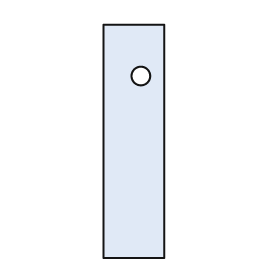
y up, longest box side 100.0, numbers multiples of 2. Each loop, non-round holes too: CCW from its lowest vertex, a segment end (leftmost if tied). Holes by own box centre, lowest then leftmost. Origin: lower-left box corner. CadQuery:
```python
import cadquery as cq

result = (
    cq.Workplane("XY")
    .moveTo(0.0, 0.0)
    .lineTo(26.0, 0.0)
    .lineTo(26.0, 100.0)
    .lineTo(0.0, 100.0)
    .close()
    .moveTo(16.0, 78.0)
    .circle(4.0)
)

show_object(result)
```